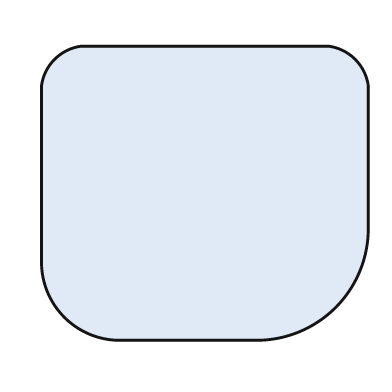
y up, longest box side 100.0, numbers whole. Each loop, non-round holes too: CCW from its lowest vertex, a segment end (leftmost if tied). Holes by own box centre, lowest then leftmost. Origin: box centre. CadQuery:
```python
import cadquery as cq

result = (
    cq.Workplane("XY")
    .moveTo(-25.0, -45.0)
    .lineTo(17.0, -45.0)
    .threePointArc((40.0, -35.0), (50.0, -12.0))
    .lineTo(50.0, 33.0)
    .threePointArc((46.0, 41.0), (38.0, 45.0))
    .lineTo(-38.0, 45.0)
    .threePointArc((-46.0, 41.0), (-50.0, 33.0))
    .lineTo(-50.0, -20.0)
    .threePointArc((-43.0, -38.0), (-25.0, -45.0))
    .close()
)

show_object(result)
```